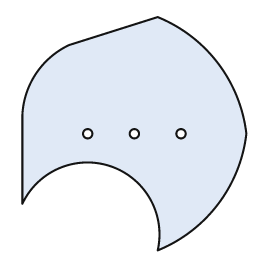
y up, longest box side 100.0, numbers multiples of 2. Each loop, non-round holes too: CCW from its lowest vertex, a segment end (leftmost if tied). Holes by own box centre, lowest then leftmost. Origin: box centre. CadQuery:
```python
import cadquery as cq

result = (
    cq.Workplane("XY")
    .moveTo(10.0, -50.0)
    .threePointArc((36.0, -30.0), (48.0, 0.0))
    .threePointArc((36.0, 30.0), (10.0, 50.0))
    .lineTo(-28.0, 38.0)
    .threePointArc((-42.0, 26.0), (-48.0, 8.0))
    .lineTo(-48.0, -30.0)
    .threePointArc((-10.0, -14.0), (10.0, -50.0))
    .close()
    .moveTo(-20.0, 0.0)
    .circle(2.0)
    .moveTo(0.0, 0.0)
    .circle(2.0)
    .moveTo(20.0, 0.0)
    .circle(2.0)
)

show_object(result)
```